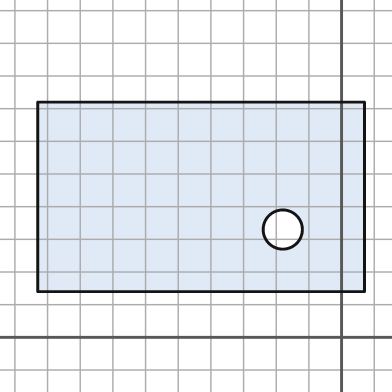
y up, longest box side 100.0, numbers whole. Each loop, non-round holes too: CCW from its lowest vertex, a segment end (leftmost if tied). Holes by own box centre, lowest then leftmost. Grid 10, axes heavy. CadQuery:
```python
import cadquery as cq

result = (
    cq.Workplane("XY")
    .moveTo(-93.0, 14.0)
    .lineTo(7.0, 14.0)
    .lineTo(7.0, 72.0)
    .lineTo(-93.0, 72.0)
    .close()
    .moveTo(-18.0, 33.0)
    .circle(6.0)
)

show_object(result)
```